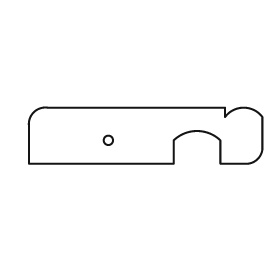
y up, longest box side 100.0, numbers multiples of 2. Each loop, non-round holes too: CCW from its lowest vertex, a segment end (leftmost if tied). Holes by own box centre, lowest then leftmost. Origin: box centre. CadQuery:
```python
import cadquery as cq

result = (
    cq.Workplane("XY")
    .moveTo(-50.0, -12.0)
    .lineTo(12.0, -12.0)
    .lineTo(12.0, -2.0)
    .threePointArc((22.0, 2.0), (32.0, -2.0))
    .lineTo(32.0, -12.0)
    .lineTo(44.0, -12.0)
    .threePointArc((48.0, -10.0), (50.0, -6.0))
    .lineTo(50.0, 8.0)
    .threePointArc((42.0, 12.0), (34.0, 8.0))
    .lineTo(34.0, 12.0)
    .lineTo(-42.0, 12.0)
    .threePointArc((-48.0, 10.0), (-50.0, 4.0))
    .close()
    .moveTo(-16.0, -2.0)
    .circle(2.0)
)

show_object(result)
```